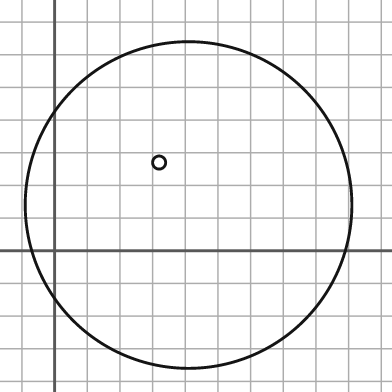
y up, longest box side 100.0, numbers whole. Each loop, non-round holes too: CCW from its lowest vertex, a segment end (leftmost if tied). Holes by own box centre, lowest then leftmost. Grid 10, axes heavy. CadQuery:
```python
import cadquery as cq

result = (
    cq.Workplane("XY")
    .moveTo(41.0, 14.0)
    .circle(50.0)
    .moveTo(32.0, 27.0)
    .circle(2.0)
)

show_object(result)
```